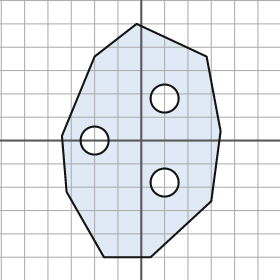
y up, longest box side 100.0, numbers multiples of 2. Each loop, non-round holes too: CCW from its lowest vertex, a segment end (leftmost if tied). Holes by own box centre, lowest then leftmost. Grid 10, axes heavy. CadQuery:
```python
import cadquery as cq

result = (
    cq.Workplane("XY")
    .moveTo(-16.0, -50.0)
    .lineTo(4.0, -50.0)
    .lineTo(30.0, -26.0)
    .lineTo(34.0, 4.0)
    .lineTo(28.0, 36.0)
    .lineTo(-2.0, 50.0)
    .lineTo(-20.0, 36.0)
    .lineTo(-34.0, 2.0)
    .lineTo(-32.0, -22.0)
    .close()
    .moveTo(10.0, -18.0)
    .circle(6.0)
    .moveTo(-20.0, 0.0)
    .circle(6.0)
    .moveTo(10.0, 18.0)
    .circle(6.0)
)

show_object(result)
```